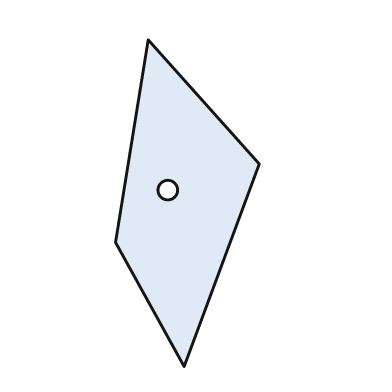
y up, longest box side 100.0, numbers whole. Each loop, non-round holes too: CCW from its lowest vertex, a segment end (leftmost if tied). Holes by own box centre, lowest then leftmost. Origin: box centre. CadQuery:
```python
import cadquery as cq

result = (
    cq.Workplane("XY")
    .moveTo(-1.0, -50.0)
    .lineTo(22.0, 12.0)
    .lineTo(-12.0, 50.0)
    .lineTo(-22.0, -12.0)
    .close()
    .moveTo(-6.0, 4.0)
    .circle(3.0)
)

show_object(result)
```